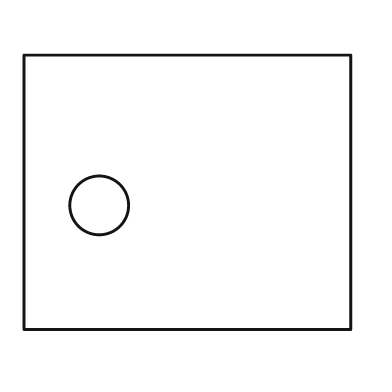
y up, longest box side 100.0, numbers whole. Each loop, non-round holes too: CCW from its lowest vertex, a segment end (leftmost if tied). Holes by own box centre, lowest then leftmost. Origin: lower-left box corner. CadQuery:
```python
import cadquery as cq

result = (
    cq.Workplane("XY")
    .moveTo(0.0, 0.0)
    .lineTo(100.0, 0.0)
    .lineTo(100.0, 84.0)
    .lineTo(0.0, 84.0)
    .close()
    .moveTo(23.0, 38.0)
    .circle(9.0)
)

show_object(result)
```